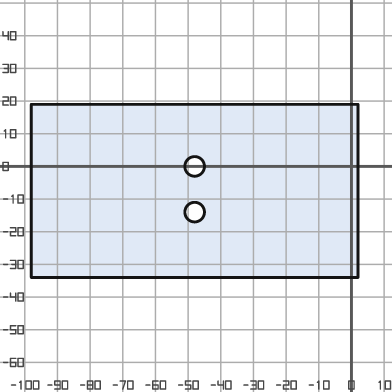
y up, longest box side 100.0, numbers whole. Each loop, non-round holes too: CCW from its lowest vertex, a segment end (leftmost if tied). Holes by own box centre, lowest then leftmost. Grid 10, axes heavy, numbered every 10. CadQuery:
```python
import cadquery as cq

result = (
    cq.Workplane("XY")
    .moveTo(-98.0, -34.0)
    .lineTo(2.0, -34.0)
    .lineTo(2.0, 19.0)
    .lineTo(-98.0, 19.0)
    .close()
    .moveTo(-48.0, -14.0)
    .circle(3.0)
    .moveTo(-48.0, 0.0)
    .circle(3.0)
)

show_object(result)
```